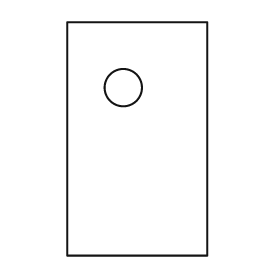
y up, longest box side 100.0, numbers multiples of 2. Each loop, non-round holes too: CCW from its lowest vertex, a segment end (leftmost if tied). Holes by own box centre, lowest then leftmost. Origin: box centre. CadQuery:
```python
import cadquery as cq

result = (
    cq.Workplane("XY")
    .moveTo(-30.0, -50.0)
    .lineTo(30.0, -50.0)
    .lineTo(30.0, 50.0)
    .lineTo(-30.0, 50.0)
    .close()
    .moveTo(-6.0, 22.0)
    .circle(8.0)
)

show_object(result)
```